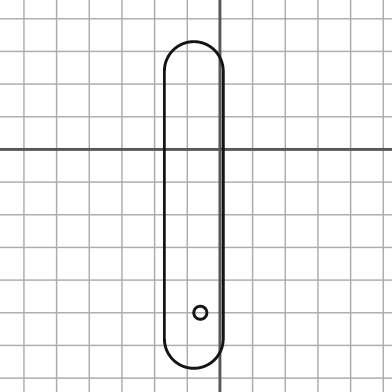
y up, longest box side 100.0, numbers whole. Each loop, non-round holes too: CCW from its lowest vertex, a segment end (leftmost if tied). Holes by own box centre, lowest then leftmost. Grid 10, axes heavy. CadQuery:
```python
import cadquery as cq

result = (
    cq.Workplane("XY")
    .moveTo(-17.0, -58.0)
    .threePointArc((-8.0, -67.0), (1.0, -58.0))
    .lineTo(1.0, 24.0)
    .threePointArc((-8.0, 33.0), (-17.0, 24.0))
    .close()
    .moveTo(-6.0, -50.0)
    .circle(2.0)
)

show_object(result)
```